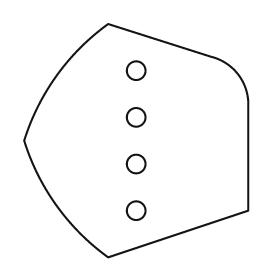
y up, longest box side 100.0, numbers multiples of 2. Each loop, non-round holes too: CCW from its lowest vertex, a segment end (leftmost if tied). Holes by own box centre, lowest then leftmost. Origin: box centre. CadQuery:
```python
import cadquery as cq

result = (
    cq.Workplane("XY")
    .moveTo(-12.0, -50.0)
    .lineTo(48.0, -30.0)
    .lineTo(48.0, 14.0)
    .threePointArc((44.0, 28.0), (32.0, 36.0))
    .lineTo(-12.0, 50.0)
    .threePointArc((-34.0, 28.0), (-48.0, 0.0))
    .threePointArc((-34.0, -28.0), (-12.0, -50.0))
    .close()
    .moveTo(0.0, -30.0)
    .circle(4.0)
    .moveTo(0.0, -10.0)
    .circle(4.0)
    .moveTo(0.0, 10.0)
    .circle(4.0)
    .moveTo(0.0, 30.0)
    .circle(4.0)
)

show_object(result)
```